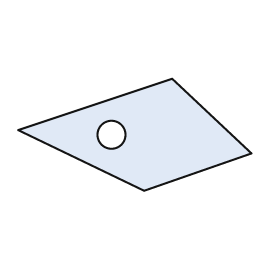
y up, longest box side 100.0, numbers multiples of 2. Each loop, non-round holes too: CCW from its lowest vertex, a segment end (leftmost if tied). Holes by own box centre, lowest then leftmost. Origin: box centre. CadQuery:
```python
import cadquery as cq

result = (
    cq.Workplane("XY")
    .moveTo(4.0, -24.0)
    .lineTo(50.0, -8.0)
    .lineTo(16.0, 24.0)
    .lineTo(-50.0, 2.0)
    .close()
    .moveTo(-10.0, 0.0)
    .circle(6.0)
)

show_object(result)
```